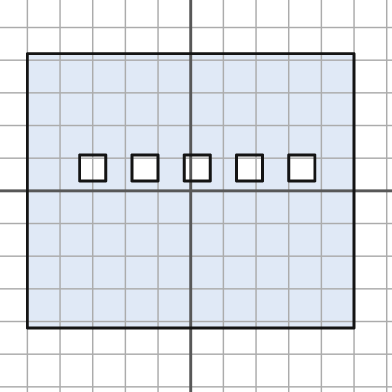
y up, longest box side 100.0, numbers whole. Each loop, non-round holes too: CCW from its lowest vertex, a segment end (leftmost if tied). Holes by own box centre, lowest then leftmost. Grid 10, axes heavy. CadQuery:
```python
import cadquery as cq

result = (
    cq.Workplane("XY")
    .moveTo(-50.0, -42.0)
    .lineTo(50.0, -42.0)
    .lineTo(50.0, 42.0)
    .lineTo(-50.0, 42.0)
    .close()
    .moveTo(-34.0, 3.0)
    .lineTo(-26.0, 3.0)
    .lineTo(-26.0, 11.0)
    .lineTo(-34.0, 11.0)
    .close()
    .moveTo(-18.0, 3.0)
    .lineTo(-10.0, 3.0)
    .lineTo(-10.0, 11.0)
    .lineTo(-18.0, 11.0)
    .close()
    .moveTo(-2.0, 3.0)
    .lineTo(6.0, 3.0)
    .lineTo(6.0, 11.0)
    .lineTo(-2.0, 11.0)
    .close()
    .moveTo(14.0, 3.0)
    .lineTo(22.0, 3.0)
    .lineTo(22.0, 11.0)
    .lineTo(14.0, 11.0)
    .close()
    .moveTo(30.0, 3.0)
    .lineTo(38.0, 3.0)
    .lineTo(38.0, 11.0)
    .lineTo(30.0, 11.0)
    .close()
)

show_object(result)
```